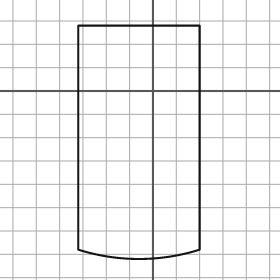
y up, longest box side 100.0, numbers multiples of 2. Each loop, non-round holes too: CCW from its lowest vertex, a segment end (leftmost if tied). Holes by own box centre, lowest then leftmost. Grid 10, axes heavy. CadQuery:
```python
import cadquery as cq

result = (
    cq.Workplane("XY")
    .moveTo(-32.0, -68.0)
    .threePointArc((-6.0, -72.0), (20.0, -68.0))
    .lineTo(20.0, 28.0)
    .lineTo(-32.0, 28.0)
    .close()
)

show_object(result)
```